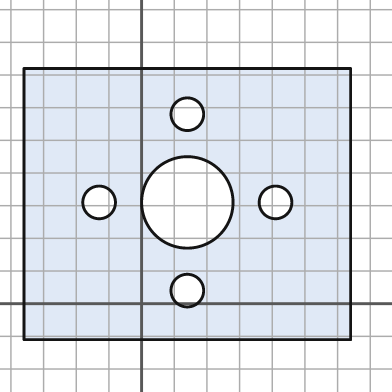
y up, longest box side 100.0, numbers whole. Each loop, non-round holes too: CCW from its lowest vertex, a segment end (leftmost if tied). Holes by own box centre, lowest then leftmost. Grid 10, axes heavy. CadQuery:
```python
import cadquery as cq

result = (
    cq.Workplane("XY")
    .moveTo(-36.0, -11.0)
    .lineTo(64.0, -11.0)
    .lineTo(64.0, 72.0)
    .lineTo(-36.0, 72.0)
    .close()
    .moveTo(14.0, 4.0)
    .circle(5.0)
    .moveTo(-13.0, 31.0)
    .circle(5.0)
    .moveTo(14.0, 31.0)
    .circle(14.0)
    .moveTo(41.0, 31.0)
    .circle(5.0)
    .moveTo(14.0, 58.0)
    .circle(5.0)
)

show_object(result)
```